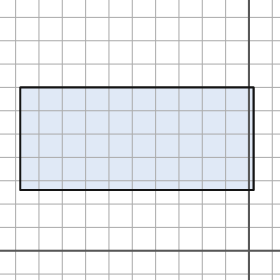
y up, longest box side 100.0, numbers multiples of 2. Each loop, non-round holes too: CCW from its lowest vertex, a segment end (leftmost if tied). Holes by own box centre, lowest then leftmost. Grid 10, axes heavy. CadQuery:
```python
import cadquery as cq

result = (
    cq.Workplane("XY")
    .moveTo(-98.0, 26.0)
    .lineTo(2.0, 26.0)
    .lineTo(2.0, 70.0)
    .lineTo(-98.0, 70.0)
    .close()
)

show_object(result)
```